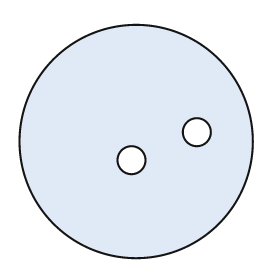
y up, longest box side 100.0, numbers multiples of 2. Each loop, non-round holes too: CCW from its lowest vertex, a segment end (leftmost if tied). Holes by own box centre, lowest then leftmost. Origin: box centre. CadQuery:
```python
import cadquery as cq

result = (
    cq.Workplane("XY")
    .moveTo(0.0, 0.0)
    .circle(50.0)
    .moveTo(-2.0, -8.0)
    .circle(6.0)
    .moveTo(26.0, 4.0)
    .circle(6.0)
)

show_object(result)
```